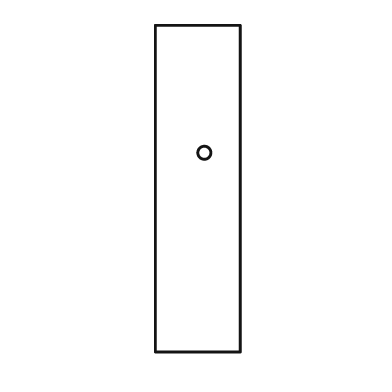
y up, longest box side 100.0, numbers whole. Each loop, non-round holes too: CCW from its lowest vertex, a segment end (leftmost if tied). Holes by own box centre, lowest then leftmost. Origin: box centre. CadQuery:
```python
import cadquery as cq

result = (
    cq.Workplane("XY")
    .moveTo(-13.0, -50.0)
    .lineTo(13.0, -50.0)
    .lineTo(13.0, 50.0)
    .lineTo(-13.0, 50.0)
    .close()
    .moveTo(2.0, 11.0)
    .circle(2.0)
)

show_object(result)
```